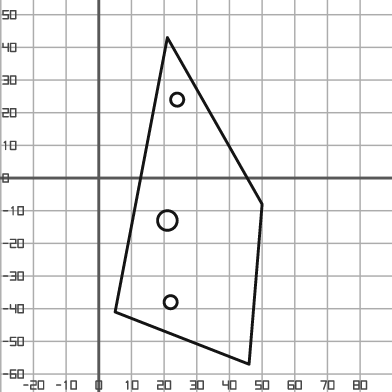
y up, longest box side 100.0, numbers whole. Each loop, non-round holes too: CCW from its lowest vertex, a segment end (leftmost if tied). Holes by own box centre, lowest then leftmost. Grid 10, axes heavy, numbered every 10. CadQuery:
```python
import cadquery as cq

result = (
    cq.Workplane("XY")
    .moveTo(46.0, -57.0)
    .lineTo(50.0, -8.0)
    .lineTo(21.0, 43.0)
    .lineTo(5.0, -41.0)
    .close()
    .moveTo(22.0, -38.0)
    .circle(2.0)
    .moveTo(21.0, -13.0)
    .circle(3.0)
    .moveTo(24.0, 24.0)
    .circle(2.0)
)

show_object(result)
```